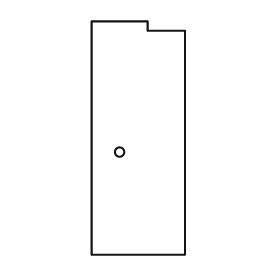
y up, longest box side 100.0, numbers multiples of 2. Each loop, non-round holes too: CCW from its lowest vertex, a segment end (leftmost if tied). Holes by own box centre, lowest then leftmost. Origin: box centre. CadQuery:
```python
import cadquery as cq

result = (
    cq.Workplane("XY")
    .moveTo(-20.0, -50.0)
    .lineTo(20.0, -50.0)
    .lineTo(20.0, 46.0)
    .lineTo(4.0, 46.0)
    .lineTo(4.0, 50.0)
    .lineTo(-20.0, 50.0)
    .close()
    .moveTo(-8.0, -6.0)
    .circle(2.0)
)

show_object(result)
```